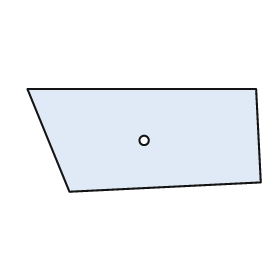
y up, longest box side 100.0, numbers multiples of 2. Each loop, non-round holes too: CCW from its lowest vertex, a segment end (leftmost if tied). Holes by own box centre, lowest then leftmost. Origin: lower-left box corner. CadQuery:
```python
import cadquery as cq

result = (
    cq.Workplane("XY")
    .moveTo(18.0, 0.0)
    .lineTo(100.0, 4.0)
    .lineTo(98.0, 44.0)
    .lineTo(0.0, 44.0)
    .close()
    .moveTo(50.0, 22.0)
    .circle(2.0)
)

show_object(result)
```